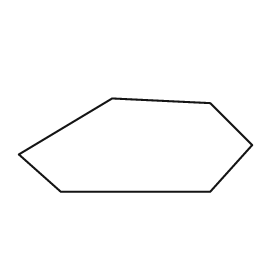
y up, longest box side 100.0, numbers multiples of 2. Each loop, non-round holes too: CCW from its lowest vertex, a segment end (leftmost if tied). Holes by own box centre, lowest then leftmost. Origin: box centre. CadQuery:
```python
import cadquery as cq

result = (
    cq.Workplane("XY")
    .moveTo(-32.0, -20.0)
    .lineTo(32.0, -20.0)
    .lineTo(50.0, 0.0)
    .lineTo(32.0, 18.0)
    .lineTo(-10.0, 20.0)
    .lineTo(-50.0, -4.0)
    .close()
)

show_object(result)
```